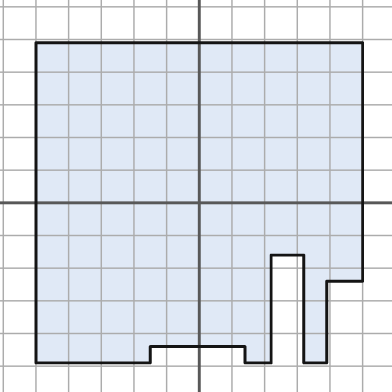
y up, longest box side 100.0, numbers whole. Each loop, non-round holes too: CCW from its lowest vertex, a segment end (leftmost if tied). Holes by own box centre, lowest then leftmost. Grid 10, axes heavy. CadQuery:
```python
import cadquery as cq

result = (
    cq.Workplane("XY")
    .moveTo(-50.0, -49.0)
    .lineTo(-15.0, -49.0)
    .lineTo(-15.0, -44.0)
    .lineTo(14.0, -44.0)
    .lineTo(14.0, -49.0)
    .lineTo(22.0, -49.0)
    .lineTo(22.0, -16.0)
    .lineTo(32.0, -16.0)
    .lineTo(32.0, -49.0)
    .lineTo(39.0, -49.0)
    .lineTo(39.0, -24.0)
    .lineTo(50.0, -24.0)
    .lineTo(50.0, 49.0)
    .lineTo(-50.0, 49.0)
    .close()
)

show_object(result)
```